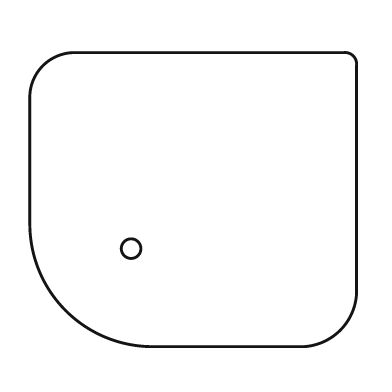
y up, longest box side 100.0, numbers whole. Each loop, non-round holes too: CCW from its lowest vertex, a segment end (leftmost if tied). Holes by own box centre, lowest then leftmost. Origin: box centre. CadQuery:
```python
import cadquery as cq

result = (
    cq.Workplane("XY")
    .moveTo(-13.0, -45.0)
    .lineTo(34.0, -45.0)
    .threePointArc((45.0, -40.0), (50.0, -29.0))
    .lineTo(50.0, 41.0)
    .threePointArc((49.0, 44.0), (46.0, 45.0))
    .lineTo(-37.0, 45.0)
    .threePointArc((-46.0, 41.0), (-50.0, 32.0))
    .lineTo(-50.0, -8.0)
    .threePointArc((-39.0, -34.0), (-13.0, -45.0))
    .close()
    .moveTo(-19.0, -15.0)
    .circle(3.0)
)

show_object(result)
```